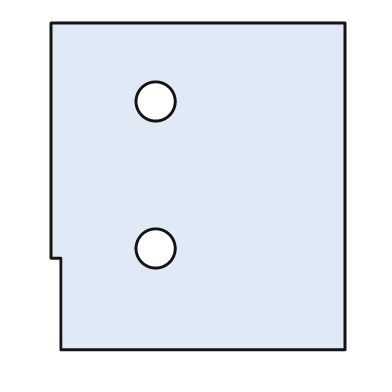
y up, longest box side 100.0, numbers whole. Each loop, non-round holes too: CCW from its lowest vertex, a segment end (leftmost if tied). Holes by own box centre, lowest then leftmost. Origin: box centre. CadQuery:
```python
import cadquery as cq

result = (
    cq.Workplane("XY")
    .moveTo(-42.0, -50.0)
    .lineTo(45.0, -50.0)
    .lineTo(45.0, 50.0)
    .lineTo(-45.0, 50.0)
    .lineTo(-45.0, -22.0)
    .lineTo(-42.0, -22.0)
    .close()
    .moveTo(-13.0, -19.0)
    .circle(6.0)
    .moveTo(-13.0, 26.0)
    .circle(6.0)
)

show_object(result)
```